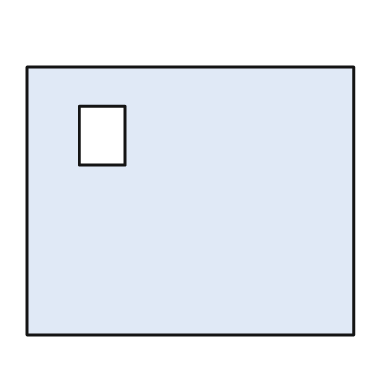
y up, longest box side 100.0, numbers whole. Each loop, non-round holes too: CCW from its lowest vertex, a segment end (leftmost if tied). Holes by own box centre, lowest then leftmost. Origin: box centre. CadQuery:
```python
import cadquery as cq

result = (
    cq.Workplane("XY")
    .moveTo(-50.0, -41.0)
    .lineTo(50.0, -41.0)
    .lineTo(50.0, 41.0)
    .lineTo(-50.0, 41.0)
    .close()
    .moveTo(-34.0, 11.0)
    .lineTo(-20.0, 11.0)
    .lineTo(-20.0, 29.0)
    .lineTo(-34.0, 29.0)
    .close()
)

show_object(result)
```